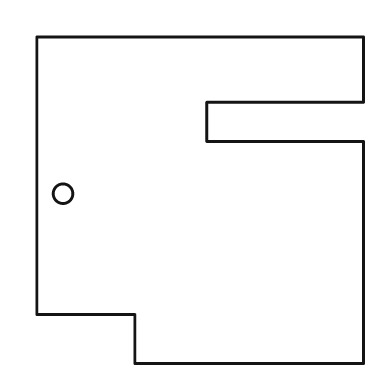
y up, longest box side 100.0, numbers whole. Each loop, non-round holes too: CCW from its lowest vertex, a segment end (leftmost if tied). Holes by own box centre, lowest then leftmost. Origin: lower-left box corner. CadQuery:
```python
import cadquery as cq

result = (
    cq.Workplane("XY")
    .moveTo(30.0, 0.0)
    .lineTo(100.0, 0.0)
    .lineTo(100.0, 68.0)
    .lineTo(52.0, 68.0)
    .lineTo(52.0, 80.0)
    .lineTo(100.0, 80.0)
    .lineTo(100.0, 100.0)
    .lineTo(0.0, 100.0)
    .lineTo(0.0, 15.0)
    .lineTo(30.0, 15.0)
    .close()
    .moveTo(8.0, 52.0)
    .circle(3.0)
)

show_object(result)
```